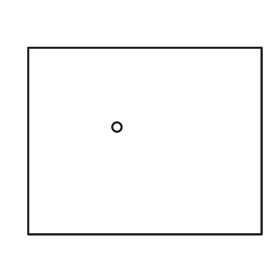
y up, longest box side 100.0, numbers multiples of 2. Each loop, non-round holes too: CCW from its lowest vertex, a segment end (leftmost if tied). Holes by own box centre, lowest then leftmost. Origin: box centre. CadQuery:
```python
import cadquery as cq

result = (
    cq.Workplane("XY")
    .moveTo(-50.0, -40.0)
    .lineTo(50.0, -40.0)
    .lineTo(50.0, 40.0)
    .lineTo(-50.0, 40.0)
    .close()
    .moveTo(-12.0, 6.0)
    .circle(2.0)
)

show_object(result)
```